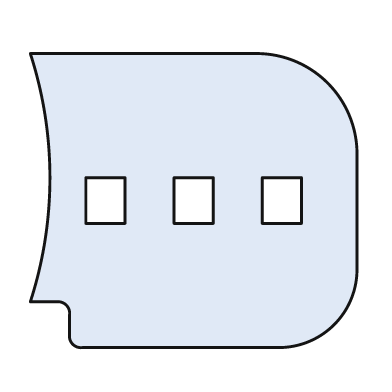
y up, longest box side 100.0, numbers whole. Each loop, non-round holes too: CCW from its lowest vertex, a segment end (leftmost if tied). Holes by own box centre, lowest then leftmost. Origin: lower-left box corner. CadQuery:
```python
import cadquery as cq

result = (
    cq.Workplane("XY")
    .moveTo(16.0, 0.0)
    .lineTo(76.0, 0.0)
    .threePointArc((93.0, 7.0), (100.0, 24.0))
    .lineTo(100.0, 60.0)
    .threePointArc((91.0, 81.0), (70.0, 90.0))
    .lineTo(0.0, 90.0)
    .threePointArc((6.0, 52.0), (0.0, 14.0))
    .lineTo(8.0, 14.0)
    .threePointArc((11.0, 13.0), (12.0, 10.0))
    .lineTo(12.0, 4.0)
    .threePointArc((13.0, 1.0), (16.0, 0.0))
    .close()
    .moveTo(17.0, 38.0)
    .lineTo(29.0, 38.0)
    .lineTo(29.0, 52.0)
    .lineTo(17.0, 52.0)
    .close()
    .moveTo(44.0, 38.0)
    .lineTo(56.0, 38.0)
    .lineTo(56.0, 52.0)
    .lineTo(44.0, 52.0)
    .close()
    .moveTo(71.0, 38.0)
    .lineTo(83.0, 38.0)
    .lineTo(83.0, 52.0)
    .lineTo(71.0, 52.0)
    .close()
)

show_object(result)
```